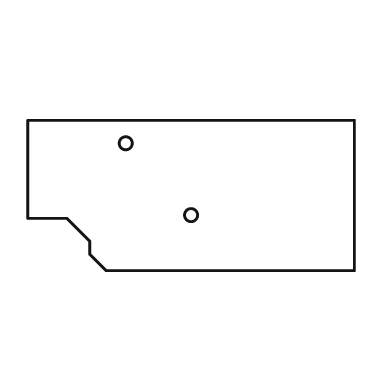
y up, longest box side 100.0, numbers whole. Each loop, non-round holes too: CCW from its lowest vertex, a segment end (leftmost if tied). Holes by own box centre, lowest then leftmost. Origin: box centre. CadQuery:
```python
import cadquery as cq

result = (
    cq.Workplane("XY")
    .moveTo(-26.0, -23.0)
    .lineTo(50.0, -23.0)
    .lineTo(50.0, 23.0)
    .lineTo(-50.0, 23.0)
    .lineTo(-50.0, -7.0)
    .lineTo(-38.0, -7.0)
    .lineTo(-31.0, -14.0)
    .lineTo(-31.0, -18.0)
    .close()
    .moveTo(0.0, -6.0)
    .circle(2.0)
    .moveTo(-20.0, 16.0)
    .circle(2.0)
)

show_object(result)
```